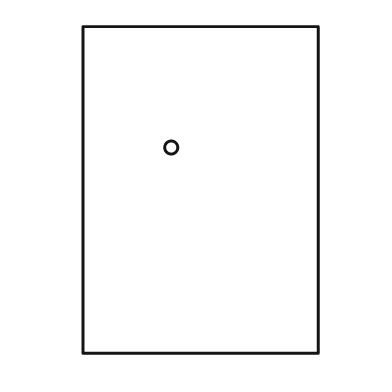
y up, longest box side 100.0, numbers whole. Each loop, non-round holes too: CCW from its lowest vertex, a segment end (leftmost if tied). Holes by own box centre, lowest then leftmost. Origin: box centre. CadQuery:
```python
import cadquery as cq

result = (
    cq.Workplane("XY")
    .moveTo(-36.0, -50.0)
    .lineTo(36.0, -50.0)
    .lineTo(36.0, 50.0)
    .lineTo(-36.0, 50.0)
    .close()
    .moveTo(-9.0, 13.0)
    .circle(2.0)
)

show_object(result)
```